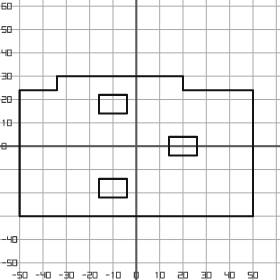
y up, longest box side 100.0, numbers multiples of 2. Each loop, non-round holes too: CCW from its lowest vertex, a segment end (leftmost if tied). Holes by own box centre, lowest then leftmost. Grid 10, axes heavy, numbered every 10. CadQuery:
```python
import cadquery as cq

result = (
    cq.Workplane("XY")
    .moveTo(-50.0, -30.0)
    .lineTo(50.0, -30.0)
    .lineTo(50.0, 24.0)
    .lineTo(20.0, 24.0)
    .lineTo(20.0, 30.0)
    .lineTo(-34.0, 30.0)
    .lineTo(-34.0, 24.0)
    .lineTo(-50.0, 24.0)
    .close()
    .moveTo(-16.0, -22.0)
    .lineTo(-4.0, -22.0)
    .lineTo(-4.0, -14.0)
    .lineTo(-16.0, -14.0)
    .close()
    .moveTo(14.0, -4.0)
    .lineTo(26.0, -4.0)
    .lineTo(26.0, 4.0)
    .lineTo(14.0, 4.0)
    .close()
    .moveTo(-16.0, 14.0)
    .lineTo(-4.0, 14.0)
    .lineTo(-4.0, 22.0)
    .lineTo(-16.0, 22.0)
    .close()
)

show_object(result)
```